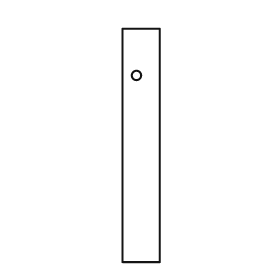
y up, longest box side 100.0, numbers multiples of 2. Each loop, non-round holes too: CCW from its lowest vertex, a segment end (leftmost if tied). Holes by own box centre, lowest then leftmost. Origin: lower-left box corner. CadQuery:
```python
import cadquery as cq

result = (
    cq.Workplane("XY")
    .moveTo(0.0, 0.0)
    .lineTo(16.0, 0.0)
    .lineTo(16.0, 100.0)
    .lineTo(0.0, 100.0)
    .close()
    .moveTo(6.0, 80.0)
    .circle(2.0)
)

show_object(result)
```